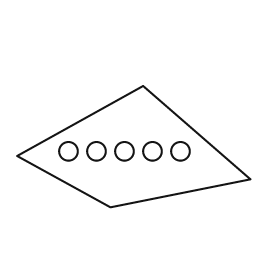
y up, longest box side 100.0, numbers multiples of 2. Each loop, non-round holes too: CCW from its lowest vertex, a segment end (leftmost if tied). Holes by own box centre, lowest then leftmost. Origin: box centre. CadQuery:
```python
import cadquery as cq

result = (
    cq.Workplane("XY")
    .moveTo(-10.0, -26.0)
    .lineTo(50.0, -14.0)
    .lineTo(4.0, 26.0)
    .lineTo(-50.0, -4.0)
    .close()
    .moveTo(-28.0, -2.0)
    .circle(4.0)
    .moveTo(-16.0, -2.0)
    .circle(4.0)
    .moveTo(-4.0, -2.0)
    .circle(4.0)
    .moveTo(8.0, -2.0)
    .circle(4.0)
    .moveTo(20.0, -2.0)
    .circle(4.0)
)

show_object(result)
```